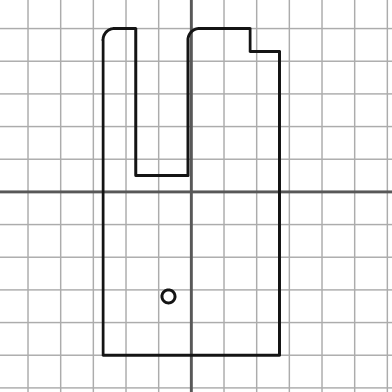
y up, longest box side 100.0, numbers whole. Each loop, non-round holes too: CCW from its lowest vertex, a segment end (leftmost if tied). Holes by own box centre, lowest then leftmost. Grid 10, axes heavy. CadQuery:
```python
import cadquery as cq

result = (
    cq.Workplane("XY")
    .moveTo(-27.0, -50.0)
    .lineTo(27.0, -50.0)
    .lineTo(27.0, 43.0)
    .lineTo(18.0, 43.0)
    .lineTo(18.0, 50.0)
    .lineTo(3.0, 50.0)
    .threePointArc((0.0, 49.0), (-1.0, 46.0))
    .lineTo(-1.0, 5.0)
    .lineTo(-17.0, 5.0)
    .lineTo(-17.0, 50.0)
    .lineTo(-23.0, 50.0)
    .threePointArc((-26.0, 49.0), (-27.0, 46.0))
    .close()
    .moveTo(-7.0, -32.0)
    .circle(2.0)
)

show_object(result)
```